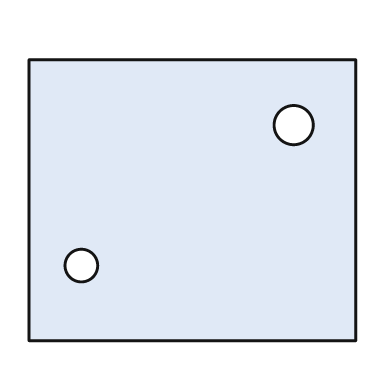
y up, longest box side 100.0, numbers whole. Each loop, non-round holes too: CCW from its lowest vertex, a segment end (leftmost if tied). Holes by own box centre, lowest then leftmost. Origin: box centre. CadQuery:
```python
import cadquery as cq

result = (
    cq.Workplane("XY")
    .moveTo(-50.0, -43.0)
    .lineTo(50.0, -43.0)
    .lineTo(50.0, 43.0)
    .lineTo(-50.0, 43.0)
    .close()
    .moveTo(-34.0, -20.0)
    .circle(5.0)
    .moveTo(31.0, 23.0)
    .circle(6.0)
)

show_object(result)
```